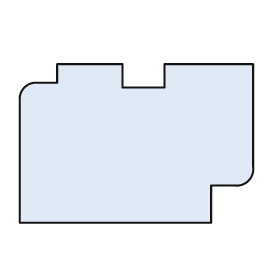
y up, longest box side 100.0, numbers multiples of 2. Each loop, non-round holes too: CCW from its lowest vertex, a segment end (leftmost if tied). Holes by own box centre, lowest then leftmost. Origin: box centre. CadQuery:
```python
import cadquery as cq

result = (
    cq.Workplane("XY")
    .moveTo(-50.0, -34.0)
    .lineTo(32.0, -34.0)
    .lineTo(32.0, -18.0)
    .lineTo(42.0, -18.0)
    .threePointArc((48.0, -16.0), (50.0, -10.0))
    .lineTo(50.0, 34.0)
    .lineTo(12.0, 34.0)
    .lineTo(12.0, 24.0)
    .lineTo(-6.0, 24.0)
    .lineTo(-6.0, 34.0)
    .lineTo(-34.0, 34.0)
    .lineTo(-34.0, 26.0)
    .lineTo(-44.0, 26.0)
    .threePointArc((-48.0, 24.0), (-50.0, 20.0))
    .close()
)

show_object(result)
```